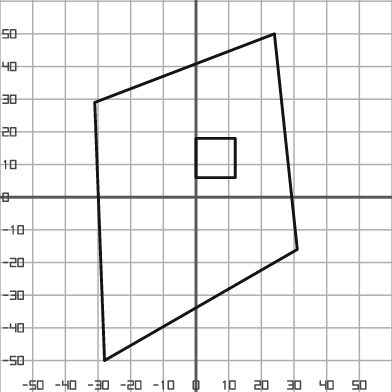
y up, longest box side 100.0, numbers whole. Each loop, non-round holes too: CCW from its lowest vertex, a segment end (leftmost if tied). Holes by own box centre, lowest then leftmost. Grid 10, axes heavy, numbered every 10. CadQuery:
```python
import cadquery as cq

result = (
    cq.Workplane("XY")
    .moveTo(-28.0, -50.0)
    .lineTo(31.0, -16.0)
    .lineTo(24.0, 50.0)
    .lineTo(-31.0, 29.0)
    .close()
    .moveTo(0.0, 6.0)
    .lineTo(12.0, 6.0)
    .lineTo(12.0, 18.0)
    .lineTo(0.0, 18.0)
    .close()
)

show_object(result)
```